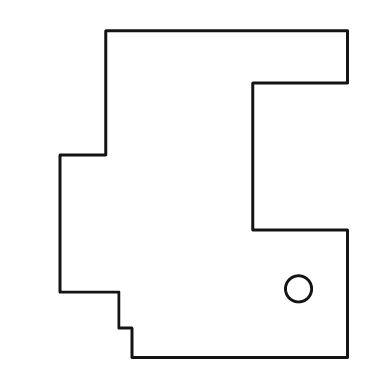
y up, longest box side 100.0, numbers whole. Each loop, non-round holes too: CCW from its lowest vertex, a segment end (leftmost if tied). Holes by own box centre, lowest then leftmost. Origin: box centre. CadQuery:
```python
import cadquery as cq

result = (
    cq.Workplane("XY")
    .moveTo(-22.0, -50.0)
    .lineTo(44.0, -50.0)
    .lineTo(44.0, -11.0)
    .lineTo(15.0, -11.0)
    .lineTo(15.0, 34.0)
    .lineTo(44.0, 34.0)
    .lineTo(44.0, 50.0)
    .lineTo(-30.0, 50.0)
    .lineTo(-30.0, 12.0)
    .lineTo(-44.0, 12.0)
    .lineTo(-44.0, -30.0)
    .lineTo(-26.0, -30.0)
    .lineTo(-26.0, -41.0)
    .lineTo(-22.0, -41.0)
    .close()
    .moveTo(29.0, -29.0)
    .circle(4.0)
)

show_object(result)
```